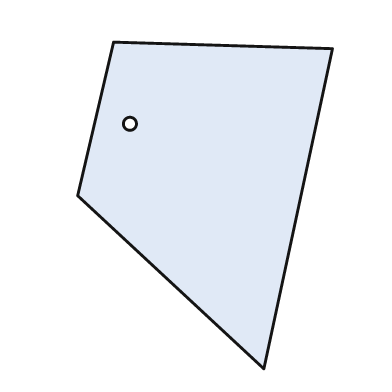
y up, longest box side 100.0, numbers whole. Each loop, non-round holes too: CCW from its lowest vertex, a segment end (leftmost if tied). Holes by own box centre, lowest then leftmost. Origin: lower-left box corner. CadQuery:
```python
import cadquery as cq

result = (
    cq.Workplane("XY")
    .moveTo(57.0, 0.0)
    .lineTo(78.0, 98.0)
    .lineTo(11.0, 100.0)
    .lineTo(0.0, 53.0)
    .close()
    .moveTo(16.0, 75.0)
    .circle(2.0)
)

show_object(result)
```